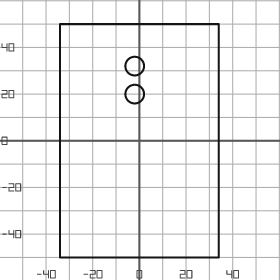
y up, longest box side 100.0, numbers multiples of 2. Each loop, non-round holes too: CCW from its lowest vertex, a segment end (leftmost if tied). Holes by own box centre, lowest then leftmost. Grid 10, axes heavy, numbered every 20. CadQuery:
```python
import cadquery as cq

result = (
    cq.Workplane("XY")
    .moveTo(-34.0, -50.0)
    .lineTo(34.0, -50.0)
    .lineTo(34.0, 50.0)
    .lineTo(-34.0, 50.0)
    .close()
    .moveTo(-2.0, 20.0)
    .circle(4.0)
    .moveTo(-2.0, 32.0)
    .circle(4.0)
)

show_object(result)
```